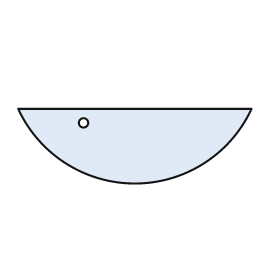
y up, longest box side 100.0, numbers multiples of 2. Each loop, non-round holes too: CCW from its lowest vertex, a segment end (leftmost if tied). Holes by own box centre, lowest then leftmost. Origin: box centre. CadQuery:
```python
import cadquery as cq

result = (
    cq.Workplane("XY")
    .moveTo(-50.0, 16.0)
    .threePointArc((0.0, -16.0), (50.0, 16.0))
    .close()
    .moveTo(-22.0, 10.0)
    .circle(2.0)
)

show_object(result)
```